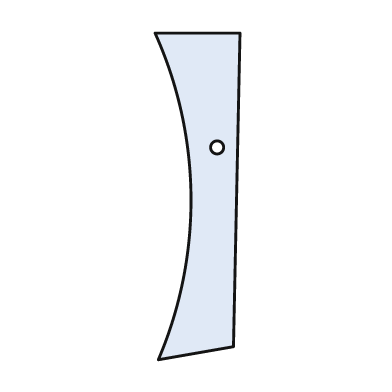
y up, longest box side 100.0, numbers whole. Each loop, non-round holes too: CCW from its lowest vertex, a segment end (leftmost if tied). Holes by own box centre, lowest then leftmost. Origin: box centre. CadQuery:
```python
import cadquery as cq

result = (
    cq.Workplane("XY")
    .moveTo(-12.0, -50.0)
    .lineTo(11.0, -46.0)
    .lineTo(13.0, 50.0)
    .lineTo(-13.0, 50.0)
    .threePointArc((-2.0, 0.0), (-12.0, -50.0))
    .close()
    .moveTo(6.0, 15.0)
    .circle(2.0)
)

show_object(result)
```